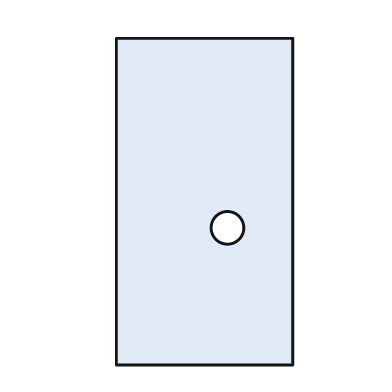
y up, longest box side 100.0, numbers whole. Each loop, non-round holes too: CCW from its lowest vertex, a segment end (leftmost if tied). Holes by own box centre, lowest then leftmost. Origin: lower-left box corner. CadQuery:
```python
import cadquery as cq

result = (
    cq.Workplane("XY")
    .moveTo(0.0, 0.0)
    .lineTo(54.0, 0.0)
    .lineTo(54.0, 100.0)
    .lineTo(0.0, 100.0)
    .close()
    .moveTo(34.0, 42.0)
    .circle(5.0)
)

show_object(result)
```